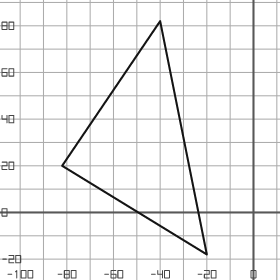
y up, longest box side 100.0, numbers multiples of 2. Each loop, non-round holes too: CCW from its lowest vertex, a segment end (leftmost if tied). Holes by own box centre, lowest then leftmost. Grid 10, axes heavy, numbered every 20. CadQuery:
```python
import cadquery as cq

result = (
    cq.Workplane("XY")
    .moveTo(-20.0, -18.0)
    .lineTo(-40.0, 82.0)
    .lineTo(-82.0, 20.0)
    .close()
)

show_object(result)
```